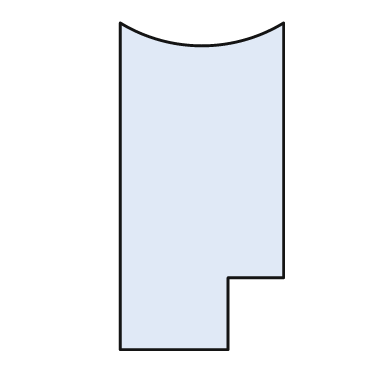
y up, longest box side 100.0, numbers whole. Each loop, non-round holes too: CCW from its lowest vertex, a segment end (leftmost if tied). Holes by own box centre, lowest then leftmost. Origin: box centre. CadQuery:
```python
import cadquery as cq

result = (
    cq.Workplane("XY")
    .moveTo(-25.0, -50.0)
    .lineTo(8.0, -50.0)
    .lineTo(8.0, -28.0)
    .lineTo(25.0, -28.0)
    .lineTo(25.0, 50.0)
    .threePointArc((0.0, 43.0), (-25.0, 50.0))
    .close()
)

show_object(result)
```